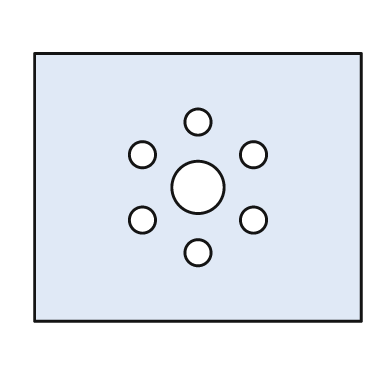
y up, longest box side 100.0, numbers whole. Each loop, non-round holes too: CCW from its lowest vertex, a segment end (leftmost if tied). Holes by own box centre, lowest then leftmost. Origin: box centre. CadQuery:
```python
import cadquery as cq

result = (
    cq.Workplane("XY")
    .moveTo(-50.0, -41.0)
    .lineTo(50.0, -41.0)
    .lineTo(50.0, 41.0)
    .lineTo(-50.0, 41.0)
    .close()
    .moveTo(0.0, -20.0)
    .circle(4.0)
    .moveTo(-17.0, -10.0)
    .circle(4.0)
    .moveTo(17.0, -10.0)
    .circle(4.0)
    .moveTo(0.0, 0.0)
    .circle(8.0)
    .moveTo(-17.0, 10.0)
    .circle(4.0)
    .moveTo(17.0, 10.0)
    .circle(4.0)
    .moveTo(0.0, 20.0)
    .circle(4.0)
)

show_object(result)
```